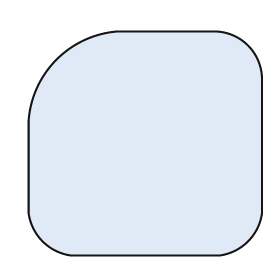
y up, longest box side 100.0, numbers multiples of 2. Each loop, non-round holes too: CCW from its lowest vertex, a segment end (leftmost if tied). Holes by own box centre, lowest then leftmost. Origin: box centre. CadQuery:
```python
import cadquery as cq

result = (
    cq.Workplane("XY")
    .moveTo(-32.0, -48.0)
    .lineTo(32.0, -48.0)
    .threePointArc((44.0, -42.0), (50.0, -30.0))
    .lineTo(50.0, 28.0)
    .threePointArc((44.0, 42.0), (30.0, 48.0))
    .lineTo(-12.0, 48.0)
    .threePointArc((-38.0, 36.0), (-50.0, 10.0))
    .lineTo(-50.0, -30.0)
    .threePointArc((-44.0, -42.0), (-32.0, -48.0))
    .close()
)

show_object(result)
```